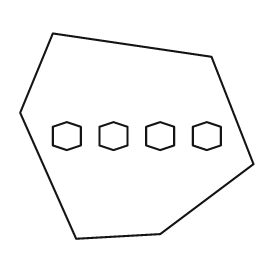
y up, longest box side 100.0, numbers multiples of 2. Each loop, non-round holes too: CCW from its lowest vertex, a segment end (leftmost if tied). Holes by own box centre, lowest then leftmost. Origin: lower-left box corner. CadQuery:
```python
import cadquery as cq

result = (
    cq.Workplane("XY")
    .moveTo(24.0, 0.0)
    .lineTo(60.0, 2.0)
    .lineTo(100.0, 32.0)
    .lineTo(82.0, 78.0)
    .lineTo(14.0, 88.0)
    .lineTo(0.0, 54.0)
    .close()
    .moveTo(20.0, 38.0)
    .lineTo(26.0, 40.0)
    .lineTo(26.0, 48.0)
    .lineTo(20.0, 50.0)
    .lineTo(14.0, 48.0)
    .lineTo(14.0, 40.0)
    .close()
    .moveTo(40.0, 38.0)
    .lineTo(46.0, 40.0)
    .lineTo(46.0, 48.0)
    .lineTo(40.0, 50.0)
    .lineTo(34.0, 48.0)
    .lineTo(34.0, 40.0)
    .close()
    .moveTo(60.0, 38.0)
    .lineTo(66.0, 40.0)
    .lineTo(66.0, 48.0)
    .lineTo(60.0, 50.0)
    .lineTo(54.0, 48.0)
    .lineTo(54.0, 40.0)
    .close()
    .moveTo(80.0, 38.0)
    .lineTo(86.0, 40.0)
    .lineTo(86.0, 48.0)
    .lineTo(80.0, 50.0)
    .lineTo(74.0, 48.0)
    .lineTo(74.0, 40.0)
    .close()
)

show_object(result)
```